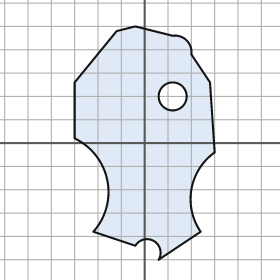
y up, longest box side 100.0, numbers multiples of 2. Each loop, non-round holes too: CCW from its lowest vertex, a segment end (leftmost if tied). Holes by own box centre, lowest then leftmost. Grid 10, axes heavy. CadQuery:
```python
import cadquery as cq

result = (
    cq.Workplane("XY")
    .moveTo(6.0, -50.0)
    .lineTo(24.0, -38.0)
    .threePointArc((20.0, -20.0), (30.0, -4.0))
    .lineTo(28.0, 26.0)
    .lineTo(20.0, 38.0)
    .threePointArc((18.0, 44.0), (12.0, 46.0))
    .lineTo(-4.0, 50.0)
    .lineTo(-12.0, 48.0)
    .lineTo(-30.0, 26.0)
    .lineTo(-30.0, 2.0)
    .threePointArc((-16.0, -16.0), (-22.0, -38.0))
    .lineTo(-4.0, -44.0)
    .threePointArc((4.0, -42.0), (6.0, -50.0))
    .close()
    .moveTo(12.0, 20.0)
    .circle(6.0)
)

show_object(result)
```